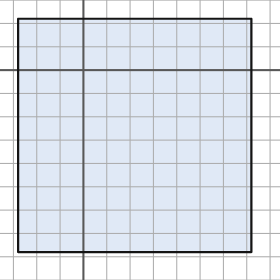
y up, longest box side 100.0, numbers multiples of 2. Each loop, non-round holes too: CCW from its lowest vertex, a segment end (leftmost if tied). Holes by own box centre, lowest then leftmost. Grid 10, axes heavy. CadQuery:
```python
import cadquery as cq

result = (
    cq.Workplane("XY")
    .moveTo(-28.0, -78.0)
    .lineTo(72.0, -78.0)
    .lineTo(72.0, 22.0)
    .lineTo(-28.0, 22.0)
    .close()
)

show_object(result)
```